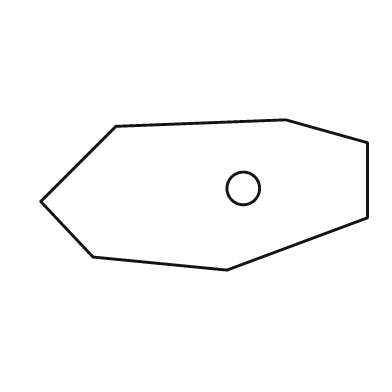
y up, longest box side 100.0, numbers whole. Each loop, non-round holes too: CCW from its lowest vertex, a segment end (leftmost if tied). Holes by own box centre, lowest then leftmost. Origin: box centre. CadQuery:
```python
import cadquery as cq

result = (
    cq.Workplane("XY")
    .moveTo(7.0, -23.0)
    .lineTo(50.0, -7.0)
    .lineTo(50.0, 16.0)
    .lineTo(25.0, 23.0)
    .lineTo(-27.0, 21.0)
    .lineTo(-50.0, -2.0)
    .lineTo(-34.0, -19.0)
    .close()
    .moveTo(12.0, 2.0)
    .circle(5.0)
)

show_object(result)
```